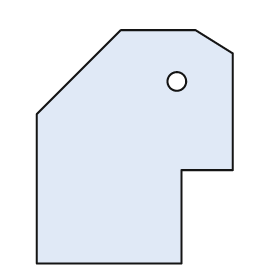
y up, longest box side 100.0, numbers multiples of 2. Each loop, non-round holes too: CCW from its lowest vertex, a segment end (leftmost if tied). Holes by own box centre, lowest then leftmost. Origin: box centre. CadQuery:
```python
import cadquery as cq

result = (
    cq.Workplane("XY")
    .moveTo(-42.0, -50.0)
    .lineTo(20.0, -50.0)
    .lineTo(20.0, -10.0)
    .lineTo(42.0, -10.0)
    .lineTo(42.0, 40.0)
    .lineTo(26.0, 50.0)
    .lineTo(-6.0, 50.0)
    .lineTo(-42.0, 14.0)
    .close()
    .moveTo(18.0, 28.0)
    .circle(4.0)
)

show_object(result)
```